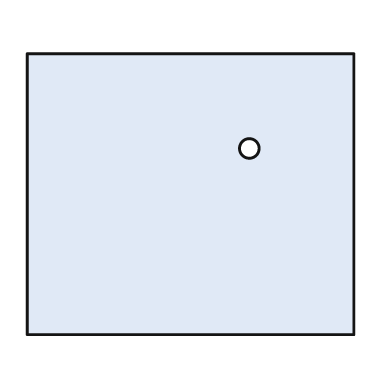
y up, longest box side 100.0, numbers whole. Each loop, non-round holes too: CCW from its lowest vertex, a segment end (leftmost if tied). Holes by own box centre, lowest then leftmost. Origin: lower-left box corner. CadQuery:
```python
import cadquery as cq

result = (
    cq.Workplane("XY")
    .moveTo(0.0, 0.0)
    .lineTo(100.0, 0.0)
    .lineTo(100.0, 86.0)
    .lineTo(0.0, 86.0)
    .close()
    .moveTo(68.0, 57.0)
    .circle(3.0)
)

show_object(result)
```